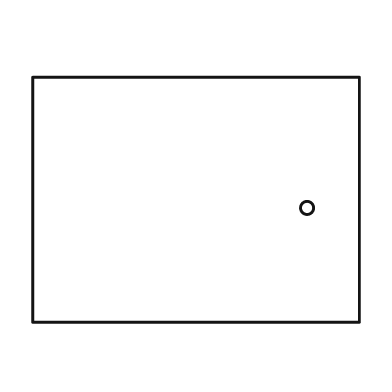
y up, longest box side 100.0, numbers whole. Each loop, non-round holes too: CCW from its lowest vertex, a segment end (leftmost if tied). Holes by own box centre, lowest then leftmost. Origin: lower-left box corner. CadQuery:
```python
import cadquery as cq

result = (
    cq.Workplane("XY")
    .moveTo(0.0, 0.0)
    .lineTo(100.0, 0.0)
    .lineTo(100.0, 75.0)
    .lineTo(0.0, 75.0)
    .close()
    .moveTo(84.0, 35.0)
    .circle(2.0)
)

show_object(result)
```